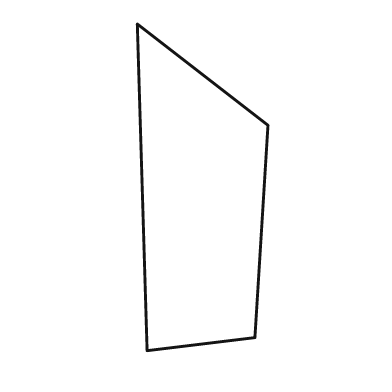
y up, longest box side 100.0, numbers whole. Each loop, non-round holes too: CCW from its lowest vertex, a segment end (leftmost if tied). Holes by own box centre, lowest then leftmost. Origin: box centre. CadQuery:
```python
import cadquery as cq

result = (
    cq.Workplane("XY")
    .moveTo(-17.0, -50.0)
    .lineTo(16.0, -46.0)
    .lineTo(20.0, 19.0)
    .lineTo(-20.0, 50.0)
    .close()
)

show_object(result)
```